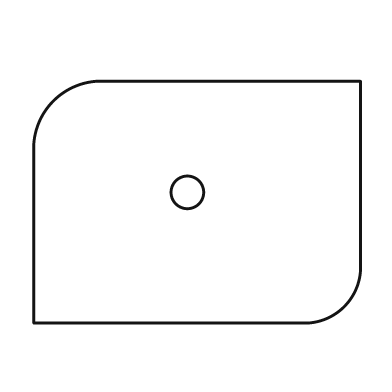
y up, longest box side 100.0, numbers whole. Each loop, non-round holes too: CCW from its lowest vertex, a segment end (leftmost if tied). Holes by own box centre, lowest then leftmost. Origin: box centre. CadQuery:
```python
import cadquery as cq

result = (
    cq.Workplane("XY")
    .moveTo(-50.0, -37.0)
    .lineTo(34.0, -37.0)
    .threePointArc((45.0, -32.0), (50.0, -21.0))
    .lineTo(50.0, 37.0)
    .lineTo(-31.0, 37.0)
    .threePointArc((-44.0, 31.0), (-50.0, 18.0))
    .close()
    .moveTo(-3.0, 3.0)
    .circle(5.0)
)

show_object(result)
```